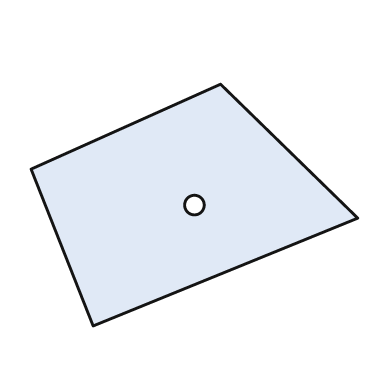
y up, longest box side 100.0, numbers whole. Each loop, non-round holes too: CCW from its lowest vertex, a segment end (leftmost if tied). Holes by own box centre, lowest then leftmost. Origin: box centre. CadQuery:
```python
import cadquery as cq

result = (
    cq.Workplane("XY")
    .moveTo(-31.0, -37.0)
    .lineTo(50.0, -4.0)
    .lineTo(8.0, 37.0)
    .lineTo(-50.0, 11.0)
    .close()
    .moveTo(0.0, 0.0)
    .circle(3.0)
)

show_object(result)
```